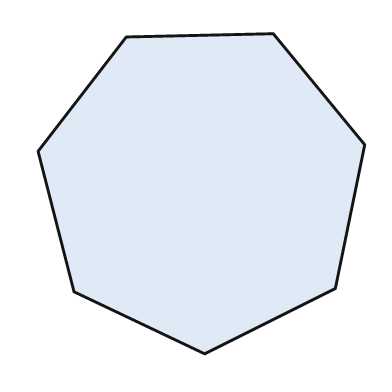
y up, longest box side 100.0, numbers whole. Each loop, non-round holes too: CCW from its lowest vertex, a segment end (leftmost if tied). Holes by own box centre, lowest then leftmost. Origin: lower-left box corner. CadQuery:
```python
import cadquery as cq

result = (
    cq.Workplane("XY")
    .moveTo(51.0, 0.0)
    .lineTo(91.0, 20.0)
    .lineTo(100.0, 64.0)
    .lineTo(72.0, 98.0)
    .lineTo(27.0, 97.0)
    .lineTo(0.0, 62.0)
    .lineTo(11.0, 19.0)
    .close()
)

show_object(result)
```